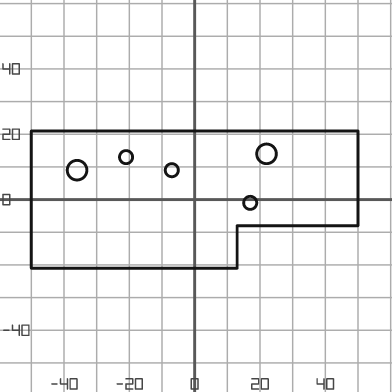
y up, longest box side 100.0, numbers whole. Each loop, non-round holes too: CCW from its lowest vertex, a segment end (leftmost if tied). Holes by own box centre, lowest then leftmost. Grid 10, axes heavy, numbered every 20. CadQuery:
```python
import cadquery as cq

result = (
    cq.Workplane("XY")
    .moveTo(-50.0, -21.0)
    .lineTo(13.0, -21.0)
    .lineTo(13.0, -8.0)
    .lineTo(50.0, -8.0)
    .lineTo(50.0, 21.0)
    .lineTo(-50.0, 21.0)
    .close()
    .moveTo(17.0, -1.0)
    .circle(2.0)
    .moveTo(-36.0, 9.0)
    .circle(3.0)
    .moveTo(-7.0, 9.0)
    .circle(2.0)
    .moveTo(-21.0, 13.0)
    .circle(2.0)
    .moveTo(22.0, 14.0)
    .circle(3.0)
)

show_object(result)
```